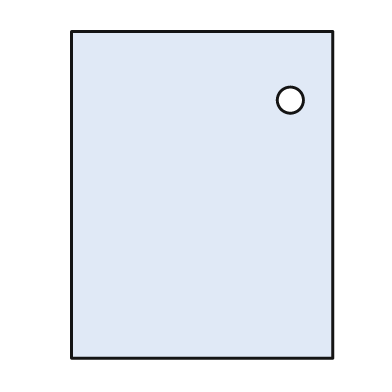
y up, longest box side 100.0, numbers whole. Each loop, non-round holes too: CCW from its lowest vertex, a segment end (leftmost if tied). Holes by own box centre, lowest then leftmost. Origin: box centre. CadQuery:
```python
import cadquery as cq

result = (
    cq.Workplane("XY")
    .moveTo(-40.0, -50.0)
    .lineTo(40.0, -50.0)
    .lineTo(40.0, 50.0)
    .lineTo(-40.0, 50.0)
    .close()
    .moveTo(27.0, 29.0)
    .circle(4.0)
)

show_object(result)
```